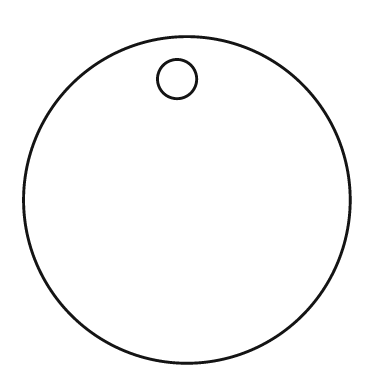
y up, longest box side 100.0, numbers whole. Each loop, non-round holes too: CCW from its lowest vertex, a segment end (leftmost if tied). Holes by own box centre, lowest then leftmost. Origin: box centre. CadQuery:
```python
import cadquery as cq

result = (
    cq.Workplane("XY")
    .moveTo(0.0, 0.0)
    .circle(50.0)
    .moveTo(-3.0, 37.0)
    .circle(6.0)
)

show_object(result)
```